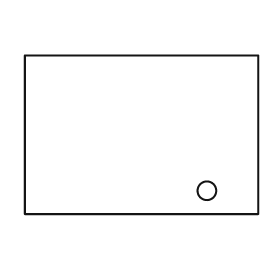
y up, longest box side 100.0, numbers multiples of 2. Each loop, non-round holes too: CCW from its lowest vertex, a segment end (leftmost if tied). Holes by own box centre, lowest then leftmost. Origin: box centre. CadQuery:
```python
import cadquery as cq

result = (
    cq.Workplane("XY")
    .moveTo(-50.0, -34.0)
    .lineTo(50.0, -34.0)
    .lineTo(50.0, 34.0)
    .lineTo(-50.0, 34.0)
    .close()
    .moveTo(28.0, -24.0)
    .circle(4.0)
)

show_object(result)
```